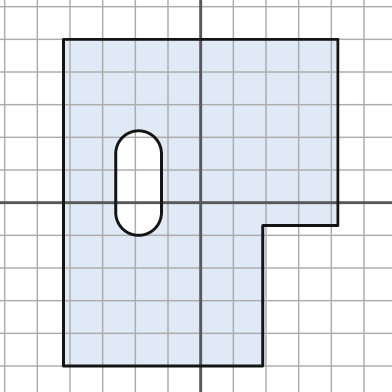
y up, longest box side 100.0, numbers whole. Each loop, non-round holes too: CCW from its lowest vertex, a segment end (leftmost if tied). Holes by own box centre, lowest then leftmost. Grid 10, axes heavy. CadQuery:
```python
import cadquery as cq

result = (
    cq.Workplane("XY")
    .moveTo(-42.0, -50.0)
    .lineTo(19.0, -50.0)
    .lineTo(19.0, -7.0)
    .lineTo(42.0, -7.0)
    .lineTo(42.0, 50.0)
    .lineTo(-42.0, 50.0)
    .close()
    .moveTo(-26.0, -3.0)
    .threePointArc((-19.0, -10.0), (-12.0, -3.0))
    .lineTo(-12.0, 15.0)
    .threePointArc((-19.0, 22.0), (-26.0, 15.0))
    .close()
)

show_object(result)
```